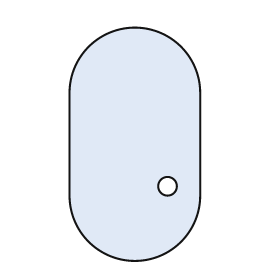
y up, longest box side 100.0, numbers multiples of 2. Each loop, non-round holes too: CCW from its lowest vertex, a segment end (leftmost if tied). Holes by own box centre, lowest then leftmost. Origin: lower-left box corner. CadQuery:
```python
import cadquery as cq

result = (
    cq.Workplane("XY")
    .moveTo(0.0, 28.0)
    .threePointArc((28.0, 0.0), (56.0, 28.0))
    .lineTo(56.0, 72.0)
    .threePointArc((28.0, 100.0), (0.0, 72.0))
    .close()
    .moveTo(42.0, 32.0)
    .circle(4.0)
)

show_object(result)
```